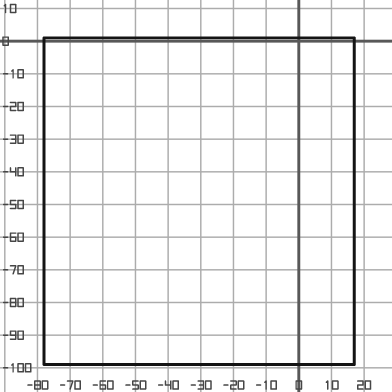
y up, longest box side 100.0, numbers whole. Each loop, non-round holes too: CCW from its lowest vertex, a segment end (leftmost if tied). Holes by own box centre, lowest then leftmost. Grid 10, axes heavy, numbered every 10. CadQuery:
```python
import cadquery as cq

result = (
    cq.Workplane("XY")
    .moveTo(-78.0, -99.0)
    .lineTo(17.0, -99.0)
    .lineTo(17.0, 1.0)
    .lineTo(-78.0, 1.0)
    .close()
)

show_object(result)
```